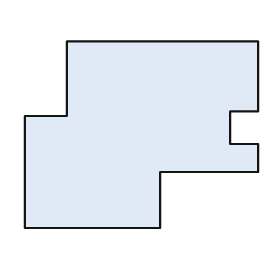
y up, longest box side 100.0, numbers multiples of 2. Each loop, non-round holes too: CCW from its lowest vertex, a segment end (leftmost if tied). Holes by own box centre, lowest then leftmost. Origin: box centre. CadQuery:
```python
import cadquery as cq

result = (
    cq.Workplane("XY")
    .moveTo(-50.0, -40.0)
    .lineTo(8.0, -40.0)
    .lineTo(8.0, -16.0)
    .lineTo(50.0, -16.0)
    .lineTo(50.0, -4.0)
    .lineTo(38.0, -4.0)
    .lineTo(38.0, 10.0)
    .lineTo(50.0, 10.0)
    .lineTo(50.0, 40.0)
    .lineTo(-32.0, 40.0)
    .lineTo(-32.0, 8.0)
    .lineTo(-50.0, 8.0)
    .close()
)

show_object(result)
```